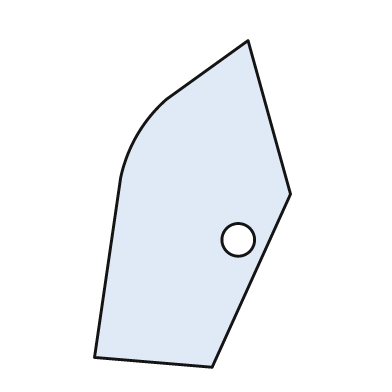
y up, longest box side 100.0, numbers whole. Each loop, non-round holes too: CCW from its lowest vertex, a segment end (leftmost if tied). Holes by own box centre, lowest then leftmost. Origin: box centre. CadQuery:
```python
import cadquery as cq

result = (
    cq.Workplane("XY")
    .moveTo(6.0, -50.0)
    .lineTo(30.0, 3.0)
    .lineTo(17.0, 50.0)
    .lineTo(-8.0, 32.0)
    .threePointArc((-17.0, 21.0), (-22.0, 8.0))
    .lineTo(-30.0, -47.0)
    .close()
    .moveTo(14.0, -11.0)
    .circle(5.0)
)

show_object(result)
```